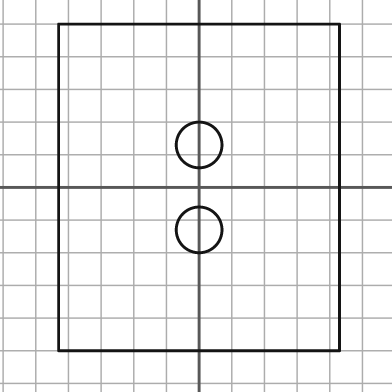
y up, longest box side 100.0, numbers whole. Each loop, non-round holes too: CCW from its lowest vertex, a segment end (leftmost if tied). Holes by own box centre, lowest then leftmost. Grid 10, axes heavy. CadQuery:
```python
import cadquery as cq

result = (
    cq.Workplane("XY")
    .moveTo(-43.0, -50.0)
    .lineTo(43.0, -50.0)
    .lineTo(43.0, 50.0)
    .lineTo(-43.0, 50.0)
    .close()
    .moveTo(0.0, -13.0)
    .circle(7.0)
    .moveTo(0.0, 13.0)
    .circle(7.0)
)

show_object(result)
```